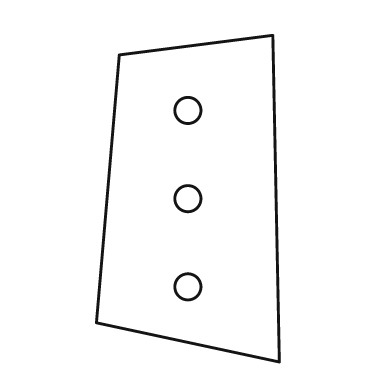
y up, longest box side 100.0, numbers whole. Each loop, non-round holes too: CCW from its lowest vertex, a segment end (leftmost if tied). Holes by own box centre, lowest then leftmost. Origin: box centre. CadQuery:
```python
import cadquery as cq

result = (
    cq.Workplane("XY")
    .moveTo(28.0, -50.0)
    .lineTo(26.0, 50.0)
    .lineTo(-21.0, 44.0)
    .lineTo(-28.0, -38.0)
    .close()
    .moveTo(0.0, -27.0)
    .circle(4.0)
    .moveTo(0.0, 0.0)
    .circle(4.0)
    .moveTo(0.0, 27.0)
    .circle(4.0)
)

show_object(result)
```